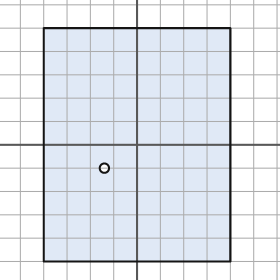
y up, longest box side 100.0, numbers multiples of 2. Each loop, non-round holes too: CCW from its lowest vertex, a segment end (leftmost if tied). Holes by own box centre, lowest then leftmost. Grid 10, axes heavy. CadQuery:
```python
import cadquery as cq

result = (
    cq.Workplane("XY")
    .moveTo(-40.0, -50.0)
    .lineTo(40.0, -50.0)
    .lineTo(40.0, 50.0)
    .lineTo(-40.0, 50.0)
    .close()
    .moveTo(-14.0, -10.0)
    .circle(2.0)
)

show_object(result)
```